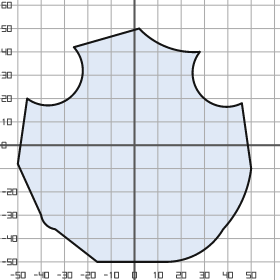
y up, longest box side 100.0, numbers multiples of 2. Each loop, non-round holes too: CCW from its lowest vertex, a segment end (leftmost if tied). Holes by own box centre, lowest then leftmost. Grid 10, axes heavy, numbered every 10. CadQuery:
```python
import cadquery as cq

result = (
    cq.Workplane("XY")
    .moveTo(-16.0, -50.0)
    .lineTo(14.0, -50.0)
    .threePointArc((28.0, -46.0), (38.0, -36.0))
    .threePointArc((46.0, -24.0), (50.0, -10.0))
    .lineTo(46.0, 18.0)
    .threePointArc((28.0, 22.0), (28.0, 40.0))
    .threePointArc((14.0, 42.0), (2.0, 50.0))
    .lineTo(-26.0, 42.0)
    .threePointArc((-26.0, 22.0), (-46.0, 20.0))
    .lineTo(-50.0, -8.0)
    .lineTo(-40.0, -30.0)
    .threePointArc((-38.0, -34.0), (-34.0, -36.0))
    .close()
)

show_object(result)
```